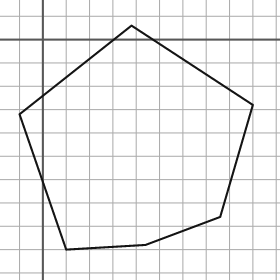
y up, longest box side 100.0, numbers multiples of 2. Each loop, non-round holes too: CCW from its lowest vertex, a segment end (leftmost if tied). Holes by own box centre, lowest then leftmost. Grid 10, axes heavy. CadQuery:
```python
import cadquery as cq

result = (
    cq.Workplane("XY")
    .moveTo(10.0, -90.0)
    .lineTo(44.0, -88.0)
    .lineTo(76.0, -76.0)
    .lineTo(90.0, -28.0)
    .lineTo(38.0, 6.0)
    .lineTo(-10.0, -32.0)
    .close()
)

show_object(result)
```